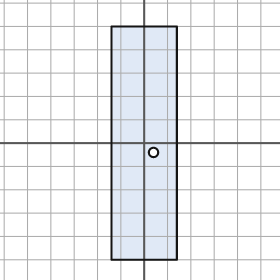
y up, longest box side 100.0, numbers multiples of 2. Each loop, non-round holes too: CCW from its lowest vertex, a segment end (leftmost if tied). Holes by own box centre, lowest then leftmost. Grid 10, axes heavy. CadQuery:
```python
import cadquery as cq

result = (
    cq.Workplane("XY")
    .moveTo(-14.0, -50.0)
    .lineTo(14.0, -50.0)
    .lineTo(14.0, 50.0)
    .lineTo(-14.0, 50.0)
    .close()
    .moveTo(4.0, -4.0)
    .circle(2.0)
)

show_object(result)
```